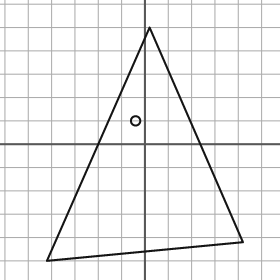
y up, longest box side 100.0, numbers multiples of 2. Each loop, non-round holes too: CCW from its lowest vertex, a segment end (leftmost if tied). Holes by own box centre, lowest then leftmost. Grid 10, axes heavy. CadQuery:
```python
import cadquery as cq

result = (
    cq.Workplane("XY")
    .moveTo(-42.0, -50.0)
    .lineTo(42.0, -42.0)
    .lineTo(2.0, 50.0)
    .close()
    .moveTo(-4.0, 10.0)
    .circle(2.0)
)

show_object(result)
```